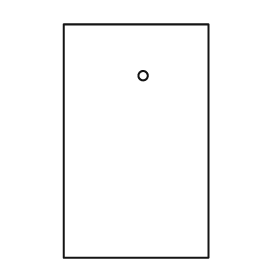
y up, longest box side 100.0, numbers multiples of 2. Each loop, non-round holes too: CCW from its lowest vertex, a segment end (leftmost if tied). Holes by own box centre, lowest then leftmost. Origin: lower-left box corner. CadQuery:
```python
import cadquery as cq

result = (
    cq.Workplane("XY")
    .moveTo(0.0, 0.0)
    .lineTo(62.0, 0.0)
    .lineTo(62.0, 100.0)
    .lineTo(0.0, 100.0)
    .close()
    .moveTo(34.0, 78.0)
    .circle(2.0)
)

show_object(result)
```